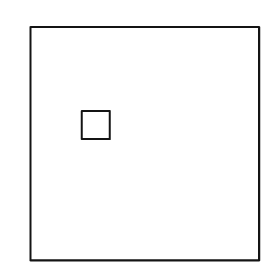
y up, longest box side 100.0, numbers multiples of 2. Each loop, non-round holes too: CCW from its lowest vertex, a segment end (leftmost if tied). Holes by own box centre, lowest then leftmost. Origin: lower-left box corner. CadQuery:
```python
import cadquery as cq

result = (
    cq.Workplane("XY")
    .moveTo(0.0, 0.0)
    .lineTo(98.0, 0.0)
    .lineTo(98.0, 100.0)
    .lineTo(0.0, 100.0)
    .close()
    .moveTo(22.0, 52.0)
    .lineTo(34.0, 52.0)
    .lineTo(34.0, 64.0)
    .lineTo(22.0, 64.0)
    .close()
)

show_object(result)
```